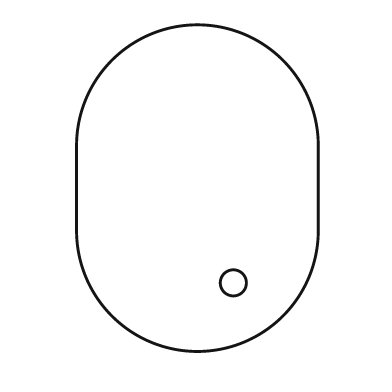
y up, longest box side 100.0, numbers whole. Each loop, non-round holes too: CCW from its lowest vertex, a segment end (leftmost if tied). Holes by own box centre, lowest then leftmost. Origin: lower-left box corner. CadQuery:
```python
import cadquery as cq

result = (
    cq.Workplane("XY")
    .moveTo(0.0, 37.0)
    .threePointArc((37.0, 0.0), (74.0, 37.0))
    .lineTo(74.0, 63.0)
    .threePointArc((37.0, 100.0), (0.0, 63.0))
    .close()
    .moveTo(48.0, 21.0)
    .circle(4.0)
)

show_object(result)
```